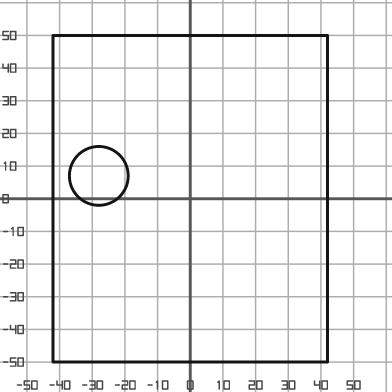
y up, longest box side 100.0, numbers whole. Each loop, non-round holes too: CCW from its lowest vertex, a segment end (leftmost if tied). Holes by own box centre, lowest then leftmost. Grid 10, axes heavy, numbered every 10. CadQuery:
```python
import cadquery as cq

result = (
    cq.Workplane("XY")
    .moveTo(-42.0, -50.0)
    .lineTo(42.0, -50.0)
    .lineTo(42.0, 50.0)
    .lineTo(-42.0, 50.0)
    .close()
    .moveTo(-28.0, 7.0)
    .circle(9.0)
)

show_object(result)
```